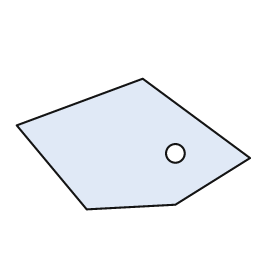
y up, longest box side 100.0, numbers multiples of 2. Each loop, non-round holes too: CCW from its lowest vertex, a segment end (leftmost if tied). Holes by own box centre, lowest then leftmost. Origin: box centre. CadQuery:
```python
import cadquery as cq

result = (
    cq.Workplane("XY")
    .moveTo(-20.0, -28.0)
    .lineTo(18.0, -26.0)
    .lineTo(50.0, -6.0)
    .lineTo(4.0, 28.0)
    .lineTo(-50.0, 8.0)
    .close()
    .moveTo(18.0, -4.0)
    .circle(4.0)
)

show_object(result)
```